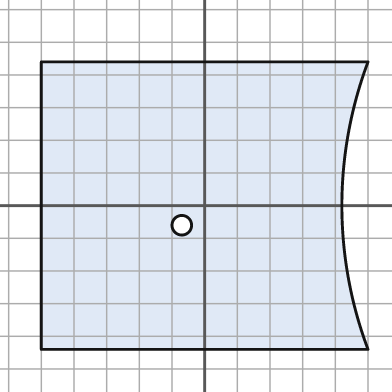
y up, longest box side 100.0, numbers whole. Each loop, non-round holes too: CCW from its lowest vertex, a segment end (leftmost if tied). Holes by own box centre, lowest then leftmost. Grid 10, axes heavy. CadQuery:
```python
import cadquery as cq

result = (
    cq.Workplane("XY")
    .moveTo(-50.0, -44.0)
    .lineTo(50.0, -44.0)
    .threePointArc((42.0, 0.0), (50.0, 44.0))
    .lineTo(-50.0, 44.0)
    .close()
    .moveTo(-7.0, -6.0)
    .circle(3.0)
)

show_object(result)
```